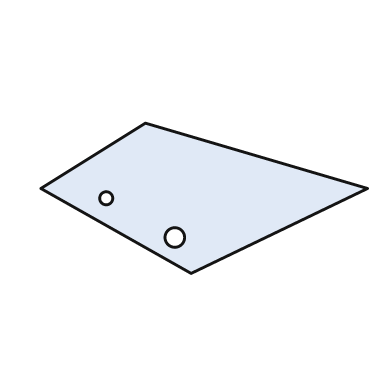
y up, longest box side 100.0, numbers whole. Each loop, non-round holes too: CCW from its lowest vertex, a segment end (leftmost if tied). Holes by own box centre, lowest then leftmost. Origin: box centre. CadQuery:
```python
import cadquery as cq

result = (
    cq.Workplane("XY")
    .moveTo(-4.0, -23.0)
    .lineTo(50.0, 3.0)
    .lineTo(-18.0, 23.0)
    .lineTo(-50.0, 3.0)
    .close()
    .moveTo(-9.0, -12.0)
    .circle(3.0)
    .moveTo(-30.0, 0.0)
    .circle(2.0)
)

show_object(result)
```